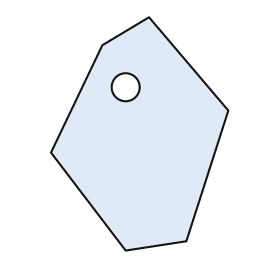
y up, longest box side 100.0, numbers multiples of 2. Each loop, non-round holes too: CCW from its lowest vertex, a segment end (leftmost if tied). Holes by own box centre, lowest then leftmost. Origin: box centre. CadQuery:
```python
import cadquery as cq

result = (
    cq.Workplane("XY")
    .moveTo(-6.0, -50.0)
    .lineTo(20.0, -46.0)
    .lineTo(38.0, 10.0)
    .lineTo(4.0, 50.0)
    .lineTo(-16.0, 38.0)
    .lineTo(-38.0, -8.0)
    .close()
    .moveTo(-6.0, 20.0)
    .circle(6.0)
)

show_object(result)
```